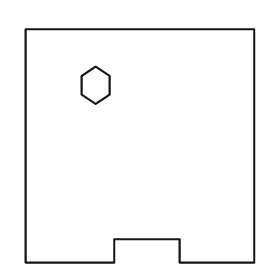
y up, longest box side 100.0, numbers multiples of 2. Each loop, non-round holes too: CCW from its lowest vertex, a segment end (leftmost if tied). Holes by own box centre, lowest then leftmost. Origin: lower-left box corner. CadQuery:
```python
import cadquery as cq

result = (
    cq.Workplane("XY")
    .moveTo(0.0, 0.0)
    .lineTo(38.0, 0.0)
    .lineTo(38.0, 10.0)
    .lineTo(66.0, 10.0)
    .lineTo(66.0, 0.0)
    .lineTo(98.0, 0.0)
    .lineTo(98.0, 100.0)
    .lineTo(0.0, 100.0)
    .close()
    .moveTo(30.0, 68.0)
    .lineTo(36.0, 72.0)
    .lineTo(36.0, 80.0)
    .lineTo(30.0, 84.0)
    .lineTo(24.0, 80.0)
    .lineTo(24.0, 72.0)
    .close()
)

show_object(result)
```